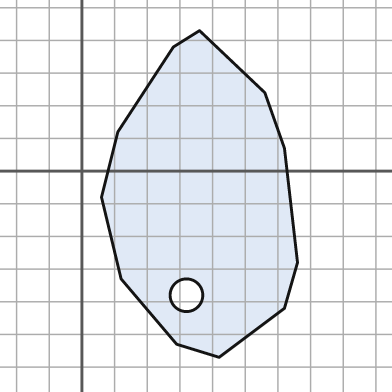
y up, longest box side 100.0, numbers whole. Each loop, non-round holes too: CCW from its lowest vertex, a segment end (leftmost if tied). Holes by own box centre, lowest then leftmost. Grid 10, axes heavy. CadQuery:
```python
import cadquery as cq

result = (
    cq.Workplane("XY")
    .moveTo(42.0, -57.0)
    .lineTo(62.0, -42.0)
    .lineTo(66.0, -28.0)
    .lineTo(62.0, 7.0)
    .lineTo(56.0, 24.0)
    .lineTo(36.0, 43.0)
    .lineTo(28.0, 38.0)
    .lineTo(11.0, 12.0)
    .lineTo(6.0, -8.0)
    .lineTo(12.0, -33.0)
    .lineTo(29.0, -53.0)
    .close()
    .moveTo(32.0, -38.0)
    .circle(5.0)
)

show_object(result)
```